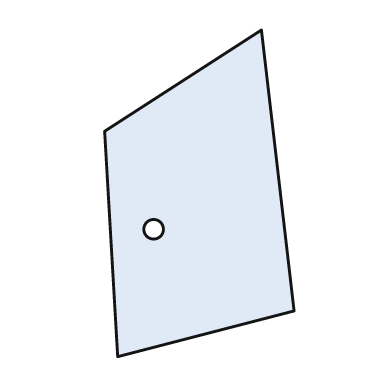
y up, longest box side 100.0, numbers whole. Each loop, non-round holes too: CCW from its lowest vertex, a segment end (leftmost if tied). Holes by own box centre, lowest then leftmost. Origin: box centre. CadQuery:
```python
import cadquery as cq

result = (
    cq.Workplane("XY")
    .moveTo(-25.0, -50.0)
    .lineTo(29.0, -36.0)
    .lineTo(19.0, 50.0)
    .lineTo(-29.0, 19.0)
    .close()
    .moveTo(-14.0, -11.0)
    .circle(3.0)
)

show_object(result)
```